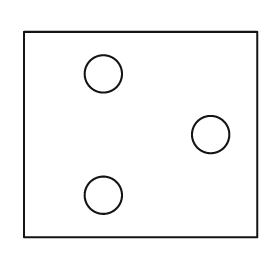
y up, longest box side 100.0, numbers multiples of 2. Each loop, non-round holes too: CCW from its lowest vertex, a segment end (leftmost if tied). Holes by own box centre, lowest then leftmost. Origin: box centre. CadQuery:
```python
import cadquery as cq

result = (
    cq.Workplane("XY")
    .moveTo(-50.0, -44.0)
    .lineTo(50.0, -44.0)
    .lineTo(50.0, 44.0)
    .lineTo(-50.0, 44.0)
    .close()
    .moveTo(-16.0, -26.0)
    .circle(8.0)
    .moveTo(30.0, 0.0)
    .circle(8.0)
    .moveTo(-16.0, 26.0)
    .circle(8.0)
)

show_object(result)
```